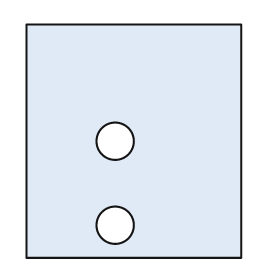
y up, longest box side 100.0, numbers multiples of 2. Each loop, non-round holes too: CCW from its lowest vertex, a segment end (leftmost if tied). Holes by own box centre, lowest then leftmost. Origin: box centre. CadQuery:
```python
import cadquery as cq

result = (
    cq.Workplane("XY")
    .moveTo(-46.0, -50.0)
    .lineTo(46.0, -50.0)
    .lineTo(46.0, 50.0)
    .lineTo(-46.0, 50.0)
    .close()
    .moveTo(-8.0, -36.0)
    .circle(8.0)
    .moveTo(-8.0, 0.0)
    .circle(8.0)
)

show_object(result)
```